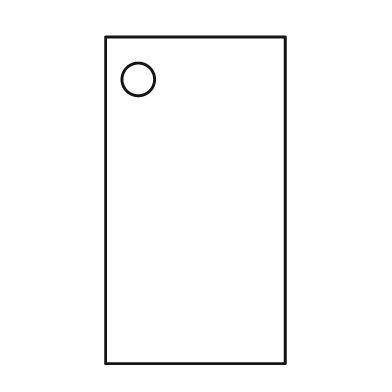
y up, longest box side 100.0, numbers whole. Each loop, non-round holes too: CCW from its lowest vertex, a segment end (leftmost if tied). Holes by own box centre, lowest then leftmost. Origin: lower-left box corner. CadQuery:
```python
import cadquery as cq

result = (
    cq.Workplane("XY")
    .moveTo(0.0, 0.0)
    .lineTo(55.0, 0.0)
    .lineTo(55.0, 100.0)
    .lineTo(0.0, 100.0)
    .close()
    .moveTo(10.0, 87.0)
    .circle(5.0)
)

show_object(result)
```